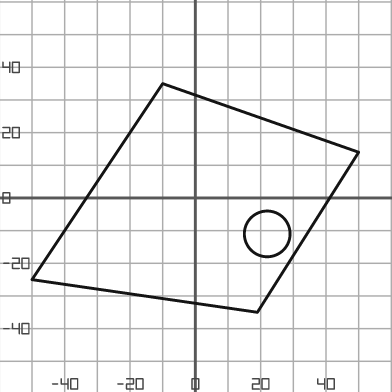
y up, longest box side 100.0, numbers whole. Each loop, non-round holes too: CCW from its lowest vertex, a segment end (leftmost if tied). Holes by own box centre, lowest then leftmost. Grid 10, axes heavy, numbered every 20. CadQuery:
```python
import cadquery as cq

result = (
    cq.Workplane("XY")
    .moveTo(19.0, -35.0)
    .lineTo(50.0, 14.0)
    .lineTo(-10.0, 35.0)
    .lineTo(-50.0, -25.0)
    .close()
    .moveTo(22.0, -11.0)
    .circle(7.0)
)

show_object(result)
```